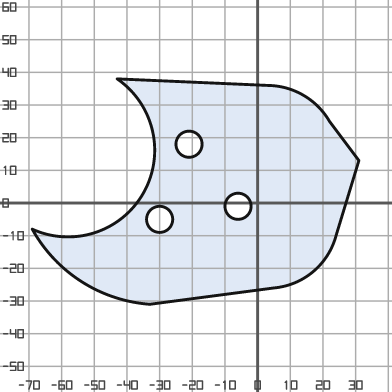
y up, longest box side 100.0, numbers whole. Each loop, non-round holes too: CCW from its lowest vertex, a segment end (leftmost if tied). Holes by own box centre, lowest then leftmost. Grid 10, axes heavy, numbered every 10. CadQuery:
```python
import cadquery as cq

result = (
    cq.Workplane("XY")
    .moveTo(-33.0, -31.0)
    .lineTo(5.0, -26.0)
    .threePointArc((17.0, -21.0), (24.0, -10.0))
    .lineTo(31.0, 13.0)
    .lineTo(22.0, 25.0)
    .threePointArc((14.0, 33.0), (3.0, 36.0))
    .lineTo(-43.0, 38.0)
    .threePointArc((-35.0, 3.0), (-69.0, -8.0))
    .threePointArc((-54.0, -24.0), (-33.0, -31.0))
    .close()
    .moveTo(-30.0, -5.0)
    .circle(4.0)
    .moveTo(-6.0, -1.0)
    .circle(4.0)
    .moveTo(-21.0, 18.0)
    .circle(4.0)
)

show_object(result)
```